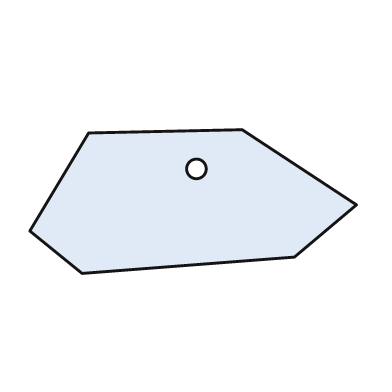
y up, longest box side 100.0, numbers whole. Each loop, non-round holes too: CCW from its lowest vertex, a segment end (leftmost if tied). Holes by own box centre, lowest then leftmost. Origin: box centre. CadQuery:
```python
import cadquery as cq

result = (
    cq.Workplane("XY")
    .moveTo(-34.0, -22.0)
    .lineTo(31.0, -17.0)
    .lineTo(50.0, -1.0)
    .lineTo(15.0, 22.0)
    .lineTo(-32.0, 21.0)
    .lineTo(-50.0, -9.0)
    .close()
    .moveTo(1.0, 10.0)
    .circle(3.0)
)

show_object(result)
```